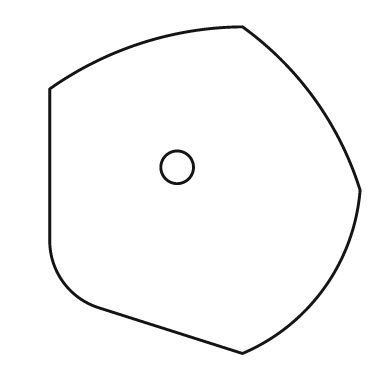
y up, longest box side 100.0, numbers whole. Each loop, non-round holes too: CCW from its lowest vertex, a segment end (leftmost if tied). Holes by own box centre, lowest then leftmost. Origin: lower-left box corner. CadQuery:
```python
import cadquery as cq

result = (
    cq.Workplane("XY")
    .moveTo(59.0, 0.0)
    .threePointArc((84.0, 20.0), (95.0, 50.0))
    .threePointArc((81.0, 78.0), (59.0, 100.0))
    .threePointArc((28.0, 95.0), (0.0, 81.0))
    .lineTo(0.0, 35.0)
    .threePointArc((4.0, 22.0), (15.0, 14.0))
    .close()
    .moveTo(39.0, 57.0)
    .circle(5.0)
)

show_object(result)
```